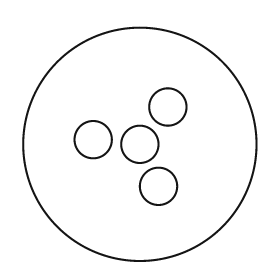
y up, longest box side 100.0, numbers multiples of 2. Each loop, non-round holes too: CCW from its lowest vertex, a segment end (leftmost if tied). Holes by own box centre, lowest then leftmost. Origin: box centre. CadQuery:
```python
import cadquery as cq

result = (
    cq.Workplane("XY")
    .moveTo(0.0, 0.0)
    .circle(50.0)
    .moveTo(8.0, -18.0)
    .circle(8.0)
    .moveTo(0.0, 0.0)
    .circle(8.0)
    .moveTo(-20.0, 2.0)
    .circle(8.0)
    .moveTo(12.0, 16.0)
    .circle(8.0)
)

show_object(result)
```